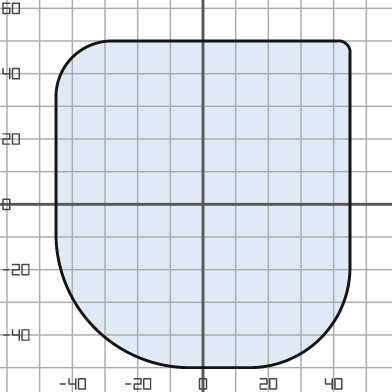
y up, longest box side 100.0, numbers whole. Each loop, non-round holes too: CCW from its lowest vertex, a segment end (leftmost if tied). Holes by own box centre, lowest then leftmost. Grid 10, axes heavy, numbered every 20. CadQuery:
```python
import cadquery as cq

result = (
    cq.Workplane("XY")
    .moveTo(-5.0, -50.0)
    .lineTo(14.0, -50.0)
    .threePointArc((36.0, -41.0), (45.0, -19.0))
    .lineTo(45.0, 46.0)
    .threePointArc((44.0, 49.0), (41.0, 50.0))
    .lineTo(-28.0, 50.0)
    .threePointArc((-40.0, 45.0), (-45.0, 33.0))
    .lineTo(-45.0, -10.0)
    .threePointArc((-33.0, -38.0), (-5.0, -50.0))
    .close()
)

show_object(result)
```